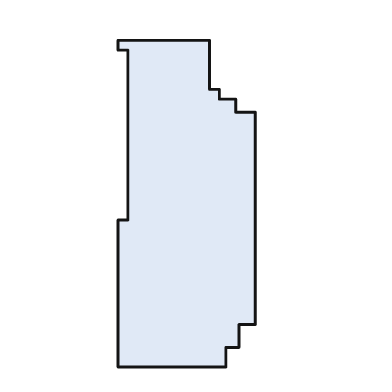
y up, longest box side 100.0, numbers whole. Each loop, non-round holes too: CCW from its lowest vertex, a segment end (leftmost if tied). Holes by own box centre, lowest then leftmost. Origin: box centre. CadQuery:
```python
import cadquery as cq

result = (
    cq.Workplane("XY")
    .moveTo(-21.0, -50.0)
    .lineTo(12.0, -50.0)
    .lineTo(12.0, -44.0)
    .lineTo(16.0, -44.0)
    .lineTo(16.0, -37.0)
    .lineTo(21.0, -37.0)
    .lineTo(21.0, 28.0)
    .lineTo(15.0, 28.0)
    .lineTo(15.0, 32.0)
    .lineTo(10.0, 32.0)
    .lineTo(10.0, 35.0)
    .lineTo(7.0, 35.0)
    .lineTo(7.0, 50.0)
    .lineTo(-21.0, 50.0)
    .lineTo(-21.0, 47.0)
    .lineTo(-18.0, 47.0)
    .lineTo(-18.0, -5.0)
    .lineTo(-21.0, -5.0)
    .close()
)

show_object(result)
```